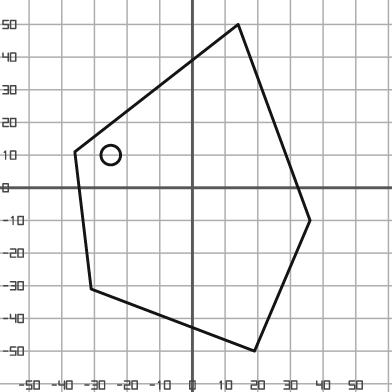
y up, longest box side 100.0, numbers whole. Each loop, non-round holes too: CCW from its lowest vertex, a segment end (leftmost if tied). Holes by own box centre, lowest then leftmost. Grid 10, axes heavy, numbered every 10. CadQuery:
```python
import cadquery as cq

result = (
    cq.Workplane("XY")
    .moveTo(19.0, -50.0)
    .lineTo(36.0, -10.0)
    .lineTo(14.0, 50.0)
    .lineTo(-36.0, 11.0)
    .lineTo(-31.0, -31.0)
    .close()
    .moveTo(-25.0, 10.0)
    .circle(3.0)
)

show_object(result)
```